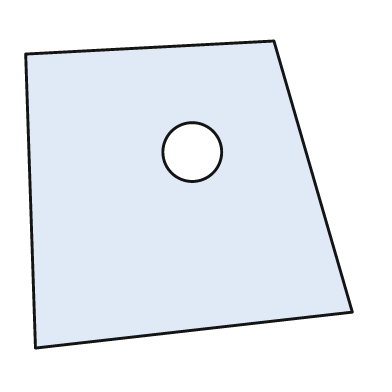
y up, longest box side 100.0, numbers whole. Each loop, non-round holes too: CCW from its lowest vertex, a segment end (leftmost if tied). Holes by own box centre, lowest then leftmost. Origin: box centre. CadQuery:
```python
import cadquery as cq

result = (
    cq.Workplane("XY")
    .moveTo(-47.0, -47.0)
    .lineTo(50.0, -36.0)
    .lineTo(26.0, 47.0)
    .lineTo(-50.0, 43.0)
    .close()
    .moveTo(1.0, 13.0)
    .circle(9.0)
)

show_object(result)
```